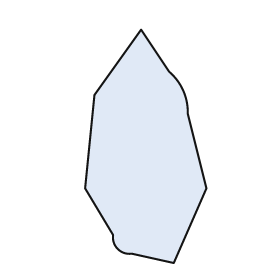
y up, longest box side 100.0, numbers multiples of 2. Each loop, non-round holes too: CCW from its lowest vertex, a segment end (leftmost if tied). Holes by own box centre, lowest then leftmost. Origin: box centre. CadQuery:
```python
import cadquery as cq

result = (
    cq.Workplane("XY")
    .moveTo(12.0, -50.0)
    .lineTo(26.0, -18.0)
    .lineTo(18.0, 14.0)
    .threePointArc((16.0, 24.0), (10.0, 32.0))
    .lineTo(-2.0, 50.0)
    .lineTo(-22.0, 22.0)
    .lineTo(-26.0, -18.0)
    .lineTo(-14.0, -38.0)
    .threePointArc((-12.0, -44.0), (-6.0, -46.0))
    .close()
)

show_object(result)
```